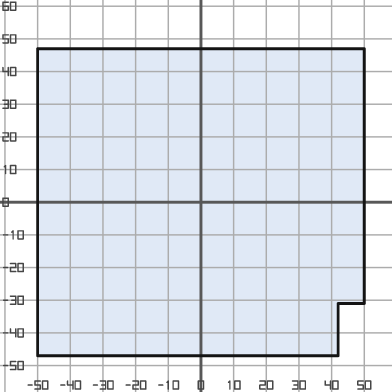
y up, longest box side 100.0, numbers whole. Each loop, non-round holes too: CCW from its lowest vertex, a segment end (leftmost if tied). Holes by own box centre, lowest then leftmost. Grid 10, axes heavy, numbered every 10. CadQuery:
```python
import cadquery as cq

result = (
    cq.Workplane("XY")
    .moveTo(-50.0, -47.0)
    .lineTo(42.0, -47.0)
    .lineTo(42.0, -31.0)
    .lineTo(50.0, -31.0)
    .lineTo(50.0, 47.0)
    .lineTo(-50.0, 47.0)
    .close()
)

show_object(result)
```